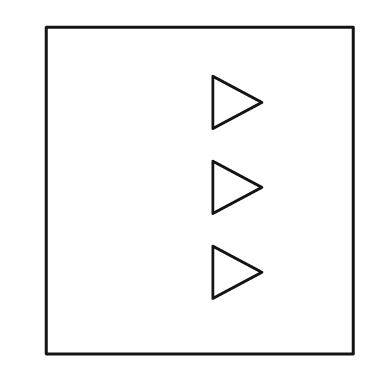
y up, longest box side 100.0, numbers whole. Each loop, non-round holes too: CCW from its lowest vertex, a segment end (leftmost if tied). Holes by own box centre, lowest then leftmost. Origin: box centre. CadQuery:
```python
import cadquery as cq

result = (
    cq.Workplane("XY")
    .moveTo(-47.0, -50.0)
    .lineTo(47.0, -50.0)
    .lineTo(47.0, 50.0)
    .lineTo(-47.0, 50.0)
    .close()
    .moveTo(4.0, -33.0)
    .lineTo(19.0, -25.0)
    .lineTo(4.0, -17.0)
    .close()
    .moveTo(4.0, -7.0)
    .lineTo(19.0, 1.0)
    .lineTo(4.0, 9.0)
    .close()
    .moveTo(4.0, 19.0)
    .lineTo(19.0, 27.0)
    .lineTo(4.0, 35.0)
    .close()
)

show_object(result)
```